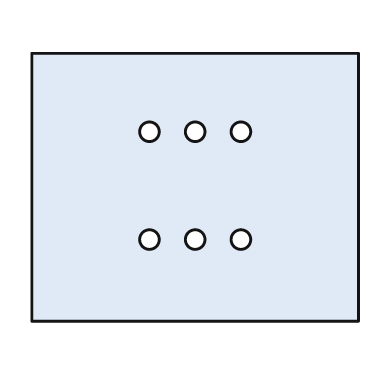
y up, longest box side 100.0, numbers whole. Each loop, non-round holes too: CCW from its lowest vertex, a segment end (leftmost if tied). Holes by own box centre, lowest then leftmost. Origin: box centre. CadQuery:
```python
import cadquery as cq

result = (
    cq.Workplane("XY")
    .moveTo(-50.0, -41.0)
    .lineTo(50.0, -41.0)
    .lineTo(50.0, 41.0)
    .lineTo(-50.0, 41.0)
    .close()
    .moveTo(-14.0, -16.0)
    .circle(3.0)
    .moveTo(0.0, -16.0)
    .circle(3.0)
    .moveTo(14.0, -16.0)
    .circle(3.0)
    .moveTo(-14.0, 17.0)
    .circle(3.0)
    .moveTo(0.0, 17.0)
    .circle(3.0)
    .moveTo(14.0, 17.0)
    .circle(3.0)
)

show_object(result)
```